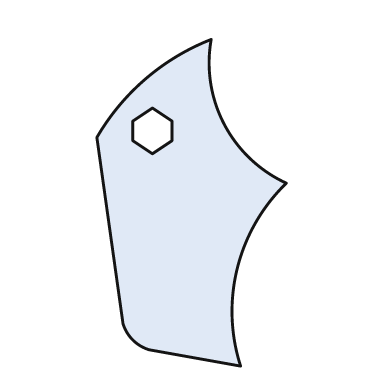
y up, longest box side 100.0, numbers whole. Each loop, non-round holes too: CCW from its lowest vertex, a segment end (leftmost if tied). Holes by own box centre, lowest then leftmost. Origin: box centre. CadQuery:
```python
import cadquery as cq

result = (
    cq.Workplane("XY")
    .moveTo(15.0, -50.0)
    .threePointArc((14.0, -20.0), (29.0, 6.0))
    .threePointArc((10.0, 24.0), (6.0, 50.0))
    .threePointArc((-14.0, 38.0), (-29.0, 20.0))
    .lineTo(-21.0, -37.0)
    .threePointArc((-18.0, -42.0), (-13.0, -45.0))
    .close()
    .moveTo(-12.0, 15.0)
    .lineTo(-6.0, 19.0)
    .lineTo(-6.0, 25.0)
    .lineTo(-12.0, 29.0)
    .lineTo(-18.0, 25.0)
    .lineTo(-18.0, 19.0)
    .close()
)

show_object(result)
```